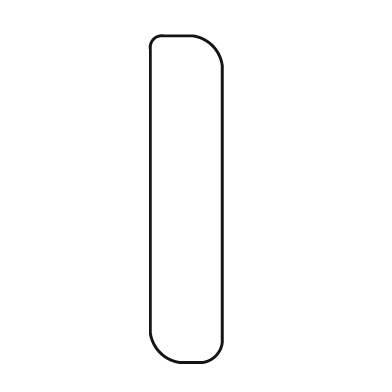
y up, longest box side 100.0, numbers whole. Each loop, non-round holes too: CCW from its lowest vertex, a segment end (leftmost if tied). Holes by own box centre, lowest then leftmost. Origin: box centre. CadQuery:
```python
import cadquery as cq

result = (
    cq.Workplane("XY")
    .moveTo(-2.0, -50.0)
    .lineTo(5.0, -50.0)
    .threePointArc((9.0, -48.0), (11.0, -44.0))
    .lineTo(11.0, 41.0)
    .threePointArc((8.0, 47.0), (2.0, 50.0))
    .lineTo(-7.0, 50.0)
    .threePointArc((-10.0, 49.0), (-11.0, 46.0))
    .lineTo(-11.0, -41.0)
    .threePointArc((-8.0, -47.0), (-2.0, -50.0))
    .close()
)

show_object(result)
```